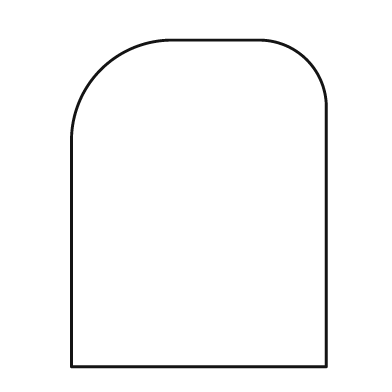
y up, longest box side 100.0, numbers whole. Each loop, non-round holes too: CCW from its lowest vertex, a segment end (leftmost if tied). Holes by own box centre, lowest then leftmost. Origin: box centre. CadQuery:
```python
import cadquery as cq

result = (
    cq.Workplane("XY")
    .moveTo(-39.0, -50.0)
    .lineTo(39.0, -50.0)
    .lineTo(39.0, 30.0)
    .threePointArc((33.0, 44.0), (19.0, 50.0))
    .lineTo(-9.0, 50.0)
    .threePointArc((-30.0, 41.0), (-39.0, 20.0))
    .close()
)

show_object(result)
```